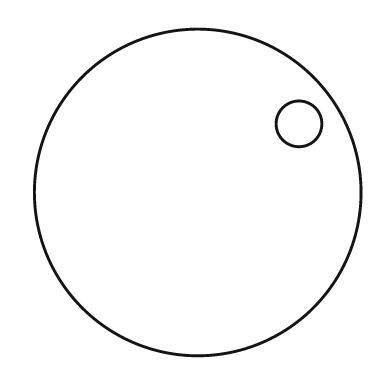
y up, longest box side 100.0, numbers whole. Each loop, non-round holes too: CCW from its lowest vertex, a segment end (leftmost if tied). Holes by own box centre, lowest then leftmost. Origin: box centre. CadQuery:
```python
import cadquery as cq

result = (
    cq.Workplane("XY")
    .moveTo(0.0, 0.0)
    .circle(50.0)
    .moveTo(31.0, 21.0)
    .circle(7.0)
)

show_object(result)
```